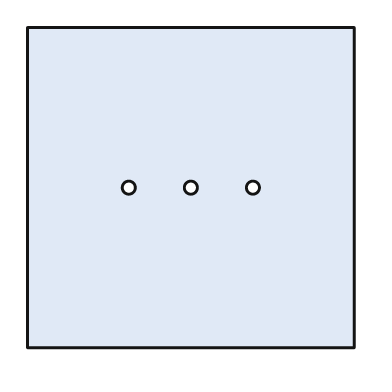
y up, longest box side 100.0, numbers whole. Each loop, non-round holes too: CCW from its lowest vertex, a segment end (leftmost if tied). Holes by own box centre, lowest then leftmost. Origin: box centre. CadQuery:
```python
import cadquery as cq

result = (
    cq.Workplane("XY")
    .moveTo(-50.0, -49.0)
    .lineTo(50.0, -49.0)
    .lineTo(50.0, 49.0)
    .lineTo(-50.0, 49.0)
    .close()
    .moveTo(-19.0, 0.0)
    .circle(2.0)
    .moveTo(0.0, 0.0)
    .circle(2.0)
    .moveTo(19.0, 0.0)
    .circle(2.0)
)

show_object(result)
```